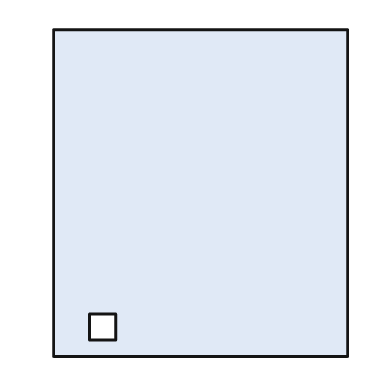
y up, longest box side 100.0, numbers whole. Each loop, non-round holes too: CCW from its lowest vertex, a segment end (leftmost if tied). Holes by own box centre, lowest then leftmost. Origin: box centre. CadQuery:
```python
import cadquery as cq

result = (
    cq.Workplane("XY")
    .moveTo(-45.0, -50.0)
    .lineTo(45.0, -50.0)
    .lineTo(45.0, 50.0)
    .lineTo(-45.0, 50.0)
    .close()
    .moveTo(-34.0, -45.0)
    .lineTo(-26.0, -45.0)
    .lineTo(-26.0, -37.0)
    .lineTo(-34.0, -37.0)
    .close()
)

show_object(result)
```